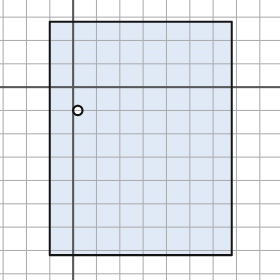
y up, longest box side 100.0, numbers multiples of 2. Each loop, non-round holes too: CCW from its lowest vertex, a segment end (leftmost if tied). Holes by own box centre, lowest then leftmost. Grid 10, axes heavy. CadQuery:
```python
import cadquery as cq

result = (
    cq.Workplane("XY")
    .moveTo(-10.0, -72.0)
    .lineTo(68.0, -72.0)
    .lineTo(68.0, 28.0)
    .lineTo(-10.0, 28.0)
    .close()
    .moveTo(2.0, -10.0)
    .circle(2.0)
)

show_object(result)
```